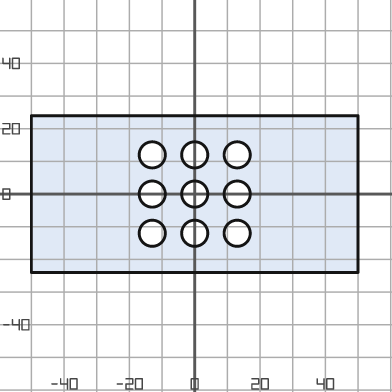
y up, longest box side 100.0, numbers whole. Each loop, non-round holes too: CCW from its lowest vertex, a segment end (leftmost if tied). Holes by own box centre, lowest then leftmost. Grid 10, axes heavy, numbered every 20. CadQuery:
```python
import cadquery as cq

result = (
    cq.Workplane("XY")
    .moveTo(-50.0, -24.0)
    .lineTo(50.0, -24.0)
    .lineTo(50.0, 24.0)
    .lineTo(-50.0, 24.0)
    .close()
    .moveTo(-13.0, -12.0)
    .circle(4.0)
    .moveTo(0.0, -12.0)
    .circle(4.0)
    .moveTo(13.0, -12.0)
    .circle(4.0)
    .moveTo(-13.0, 0.0)
    .circle(4.0)
    .moveTo(0.0, 0.0)
    .circle(4.0)
    .moveTo(13.0, 0.0)
    .circle(4.0)
    .moveTo(-13.0, 12.0)
    .circle(4.0)
    .moveTo(0.0, 12.0)
    .circle(4.0)
    .moveTo(13.0, 12.0)
    .circle(4.0)
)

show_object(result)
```